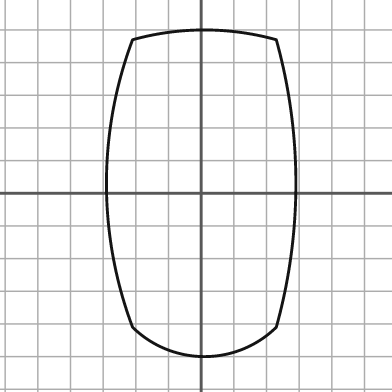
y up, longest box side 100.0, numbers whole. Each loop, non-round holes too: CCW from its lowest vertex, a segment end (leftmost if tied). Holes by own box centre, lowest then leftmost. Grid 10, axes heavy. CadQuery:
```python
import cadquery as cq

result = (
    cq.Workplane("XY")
    .moveTo(-21.0, -41.0)
    .threePointArc((1.0, -50.0), (23.0, -41.0))
    .threePointArc((29.0, 3.0), (23.0, 47.0))
    .threePointArc((1.0, 50.0), (-21.0, 47.0))
    .threePointArc((-29.0, 3.0), (-21.0, -41.0))
    .close()
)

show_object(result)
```